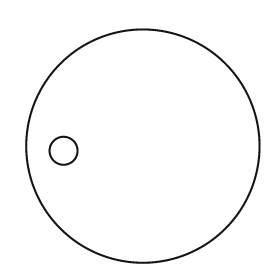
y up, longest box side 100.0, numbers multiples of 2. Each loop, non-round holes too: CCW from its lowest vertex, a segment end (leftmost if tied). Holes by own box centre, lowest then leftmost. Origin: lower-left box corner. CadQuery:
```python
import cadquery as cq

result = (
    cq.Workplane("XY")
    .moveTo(50.0, 50.0)
    .circle(50.0)
    .moveTo(16.0, 48.0)
    .circle(6.0)
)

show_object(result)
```